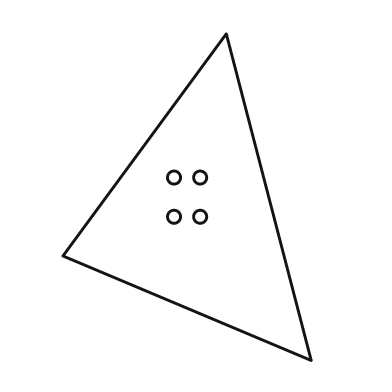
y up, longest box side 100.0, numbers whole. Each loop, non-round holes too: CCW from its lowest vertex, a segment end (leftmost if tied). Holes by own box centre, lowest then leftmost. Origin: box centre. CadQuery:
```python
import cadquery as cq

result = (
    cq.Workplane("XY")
    .moveTo(38.0, -50.0)
    .lineTo(12.0, 50.0)
    .lineTo(-38.0, -18.0)
    .close()
    .moveTo(-4.0, -6.0)
    .circle(2.0)
    .moveTo(4.0, -6.0)
    .circle(2.0)
    .moveTo(-4.0, 6.0)
    .circle(2.0)
    .moveTo(4.0, 6.0)
    .circle(2.0)
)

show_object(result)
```